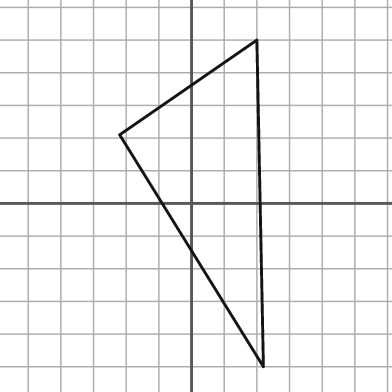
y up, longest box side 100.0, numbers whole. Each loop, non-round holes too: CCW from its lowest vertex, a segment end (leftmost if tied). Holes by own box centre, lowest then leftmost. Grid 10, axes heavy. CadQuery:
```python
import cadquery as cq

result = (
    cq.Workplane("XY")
    .moveTo(22.0, -50.0)
    .lineTo(20.0, 50.0)
    .lineTo(-22.0, 21.0)
    .close()
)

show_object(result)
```